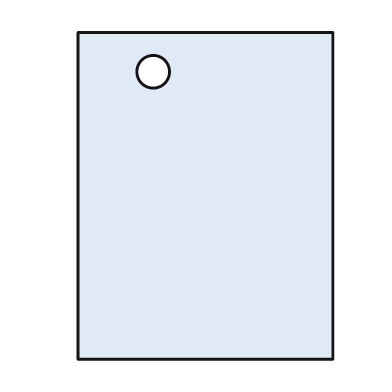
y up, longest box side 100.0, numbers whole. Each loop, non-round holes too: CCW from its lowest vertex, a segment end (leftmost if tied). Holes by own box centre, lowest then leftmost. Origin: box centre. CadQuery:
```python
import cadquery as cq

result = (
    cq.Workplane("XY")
    .moveTo(-39.0, -50.0)
    .lineTo(39.0, -50.0)
    .lineTo(39.0, 50.0)
    .lineTo(-39.0, 50.0)
    .close()
    .moveTo(-16.0, 38.0)
    .circle(5.0)
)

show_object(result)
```